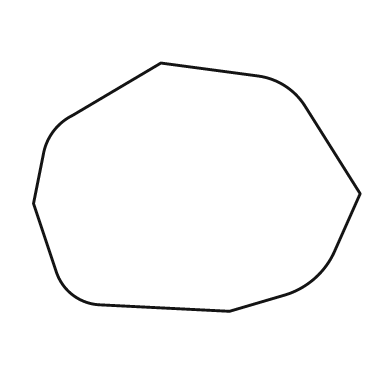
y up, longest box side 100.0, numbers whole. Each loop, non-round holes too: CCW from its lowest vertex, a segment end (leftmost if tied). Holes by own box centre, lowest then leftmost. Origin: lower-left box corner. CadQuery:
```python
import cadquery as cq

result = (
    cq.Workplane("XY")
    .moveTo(60.0, 0.0)
    .lineTo(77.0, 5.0)
    .threePointArc((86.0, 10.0), (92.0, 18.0))
    .lineTo(100.0, 36.0)
    .lineTo(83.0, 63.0)
    .threePointArc((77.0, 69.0), (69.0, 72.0))
    .lineTo(39.0, 76.0)
    .lineTo(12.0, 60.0)
    .threePointArc((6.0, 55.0), (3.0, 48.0))
    .lineTo(0.0, 33.0)
    .lineTo(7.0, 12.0)
    .threePointArc((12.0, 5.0), (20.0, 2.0))
    .close()
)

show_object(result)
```